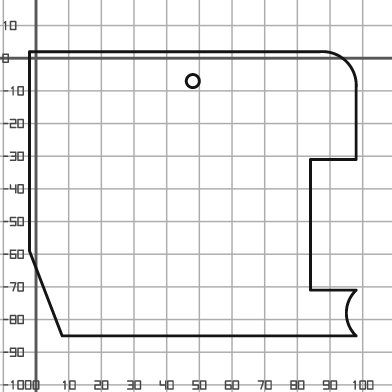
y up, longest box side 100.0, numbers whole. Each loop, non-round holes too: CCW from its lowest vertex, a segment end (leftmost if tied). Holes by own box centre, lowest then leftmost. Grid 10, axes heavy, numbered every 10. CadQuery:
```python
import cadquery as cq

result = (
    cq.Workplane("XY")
    .moveTo(8.0, -85.0)
    .lineTo(98.0, -85.0)
    .threePointArc((95.0, -78.0), (98.0, -71.0))
    .lineTo(84.0, -71.0)
    .lineTo(84.0, -31.0)
    .lineTo(98.0, -31.0)
    .lineTo(98.0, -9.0)
    .threePointArc((95.0, -1.0), (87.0, 2.0))
    .lineTo(-2.0, 2.0)
    .lineTo(-2.0, -59.0)
    .close()
    .moveTo(48.0, -7.0)
    .circle(2.0)
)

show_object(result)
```